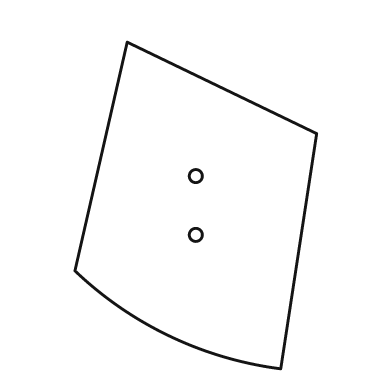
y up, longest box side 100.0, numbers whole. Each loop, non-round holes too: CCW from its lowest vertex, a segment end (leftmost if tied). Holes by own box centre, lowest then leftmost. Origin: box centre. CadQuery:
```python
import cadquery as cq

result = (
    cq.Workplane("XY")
    .moveTo(26.0, -50.0)
    .lineTo(37.0, 22.0)
    .lineTo(-21.0, 50.0)
    .lineTo(-37.0, -20.0)
    .threePointArc((-8.0, -40.0), (26.0, -50.0))
    .close()
    .moveTo(0.0, -9.0)
    .circle(2.0)
    .moveTo(0.0, 9.0)
    .circle(2.0)
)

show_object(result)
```